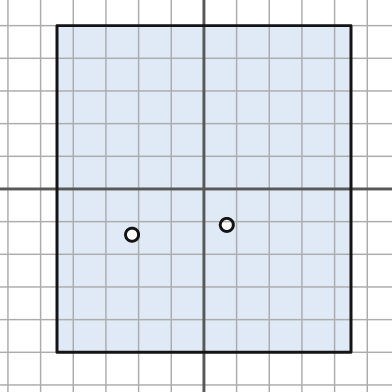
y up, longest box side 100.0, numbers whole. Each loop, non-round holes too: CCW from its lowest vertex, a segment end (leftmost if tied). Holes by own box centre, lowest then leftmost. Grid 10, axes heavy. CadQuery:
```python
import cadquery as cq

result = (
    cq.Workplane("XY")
    .moveTo(-45.0, -50.0)
    .lineTo(45.0, -50.0)
    .lineTo(45.0, 50.0)
    .lineTo(-45.0, 50.0)
    .close()
    .moveTo(-22.0, -14.0)
    .circle(2.0)
    .moveTo(7.0, -11.0)
    .circle(2.0)
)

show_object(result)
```